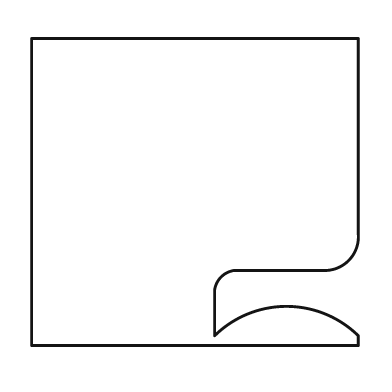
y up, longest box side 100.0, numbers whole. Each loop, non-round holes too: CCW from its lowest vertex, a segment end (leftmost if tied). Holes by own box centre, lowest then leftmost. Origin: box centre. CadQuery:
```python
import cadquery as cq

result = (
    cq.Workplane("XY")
    .moveTo(-50.0, -47.0)
    .lineTo(50.0, -47.0)
    .lineTo(50.0, -44.0)
    .threePointArc((28.0, -35.0), (6.0, -44.0))
    .lineTo(6.0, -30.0)
    .threePointArc((8.0, -26.0), (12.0, -24.0))
    .lineTo(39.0, -24.0)
    .threePointArc((47.0, -21.0), (50.0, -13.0))
    .lineTo(50.0, 47.0)
    .lineTo(-50.0, 47.0)
    .close()
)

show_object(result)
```